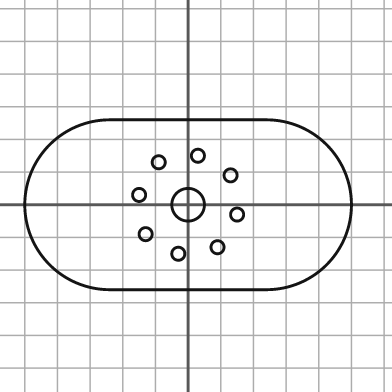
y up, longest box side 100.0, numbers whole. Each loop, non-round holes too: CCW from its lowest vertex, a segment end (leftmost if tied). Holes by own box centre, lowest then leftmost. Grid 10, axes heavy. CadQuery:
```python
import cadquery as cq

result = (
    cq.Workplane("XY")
    .moveTo(-24.0, -26.0)
    .lineTo(24.0, -26.0)
    .threePointArc((50.0, 0.0), (24.0, 26.0))
    .lineTo(-24.0, 26.0)
    .threePointArc((-50.0, 0.0), (-24.0, -26.0))
    .close()
    .moveTo(-3.0, -15.0)
    .circle(2.0)
    .moveTo(9.0, -13.0)
    .circle(2.0)
    .moveTo(-13.0, -9.0)
    .circle(2.0)
    .moveTo(15.0, -3.0)
    .circle(2.0)
    .moveTo(0.0, 0.0)
    .circle(5.0)
    .moveTo(-15.0, 3.0)
    .circle(2.0)
    .moveTo(13.0, 9.0)
    .circle(2.0)
    .moveTo(-9.0, 13.0)
    .circle(2.0)
    .moveTo(3.0, 15.0)
    .circle(2.0)
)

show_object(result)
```